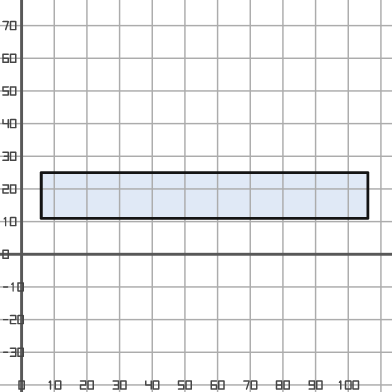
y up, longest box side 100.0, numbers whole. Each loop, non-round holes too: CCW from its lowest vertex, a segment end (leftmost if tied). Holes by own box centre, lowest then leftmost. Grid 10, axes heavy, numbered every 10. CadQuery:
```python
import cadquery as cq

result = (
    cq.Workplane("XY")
    .moveTo(6.0, 11.0)
    .lineTo(106.0, 11.0)
    .lineTo(106.0, 25.0)
    .lineTo(6.0, 25.0)
    .close()
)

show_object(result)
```